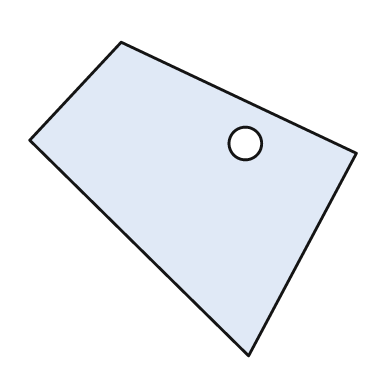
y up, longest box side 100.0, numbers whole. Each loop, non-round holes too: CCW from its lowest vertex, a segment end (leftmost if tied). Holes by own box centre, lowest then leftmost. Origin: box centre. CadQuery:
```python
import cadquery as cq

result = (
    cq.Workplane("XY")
    .moveTo(17.0, -48.0)
    .lineTo(50.0, 14.0)
    .lineTo(-22.0, 48.0)
    .lineTo(-50.0, 18.0)
    .close()
    .moveTo(16.0, 17.0)
    .circle(5.0)
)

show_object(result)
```